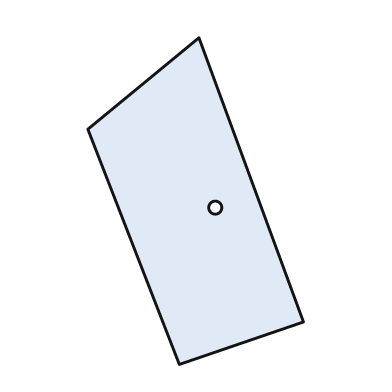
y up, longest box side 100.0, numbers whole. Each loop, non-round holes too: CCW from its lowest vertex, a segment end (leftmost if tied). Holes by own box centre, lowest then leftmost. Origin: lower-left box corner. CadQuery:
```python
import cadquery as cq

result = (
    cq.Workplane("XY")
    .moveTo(28.0, 0.0)
    .lineTo(66.0, 13.0)
    .lineTo(34.0, 100.0)
    .lineTo(0.0, 72.0)
    .close()
    .moveTo(39.0, 48.0)
    .circle(2.0)
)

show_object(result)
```